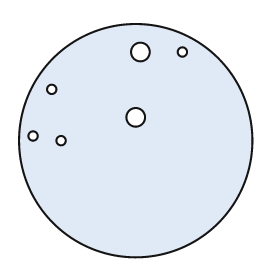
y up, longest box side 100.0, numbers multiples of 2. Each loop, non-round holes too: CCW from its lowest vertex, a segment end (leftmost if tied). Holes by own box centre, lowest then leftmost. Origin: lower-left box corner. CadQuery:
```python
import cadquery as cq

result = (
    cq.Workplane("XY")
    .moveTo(50.0, 50.0)
    .circle(50.0)
    .moveTo(18.0, 50.0)
    .circle(2.0)
    .moveTo(6.0, 52.0)
    .circle(2.0)
    .moveTo(50.0, 60.0)
    .circle(4.0)
    .moveTo(14.0, 72.0)
    .circle(2.0)
    .moveTo(52.0, 88.0)
    .circle(4.0)
    .moveTo(70.0, 88.0)
    .circle(2.0)
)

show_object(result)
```